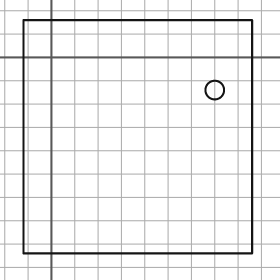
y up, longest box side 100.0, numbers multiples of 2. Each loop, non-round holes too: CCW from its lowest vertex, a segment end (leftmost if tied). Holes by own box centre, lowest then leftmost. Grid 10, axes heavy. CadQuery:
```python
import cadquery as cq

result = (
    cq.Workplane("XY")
    .moveTo(-12.0, -84.0)
    .lineTo(86.0, -84.0)
    .lineTo(86.0, 16.0)
    .lineTo(-12.0, 16.0)
    .close()
    .moveTo(70.0, -14.0)
    .circle(4.0)
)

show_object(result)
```